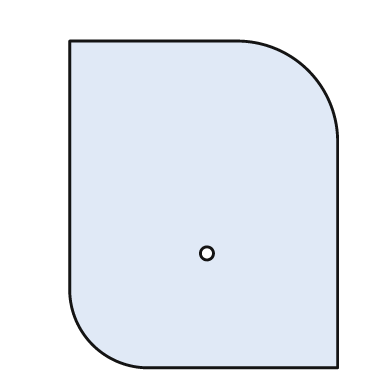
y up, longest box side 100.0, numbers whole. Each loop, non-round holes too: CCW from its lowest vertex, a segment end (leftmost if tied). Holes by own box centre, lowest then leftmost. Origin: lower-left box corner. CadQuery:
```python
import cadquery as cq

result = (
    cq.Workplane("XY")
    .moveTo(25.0, 0.0)
    .lineTo(82.0, 0.0)
    .lineTo(82.0, 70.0)
    .threePointArc((73.0, 91.0), (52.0, 100.0))
    .lineTo(0.0, 100.0)
    .lineTo(0.0, 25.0)
    .threePointArc((7.0, 7.0), (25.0, 0.0))
    .close()
    .moveTo(42.0, 35.0)
    .circle(2.0)
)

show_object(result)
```